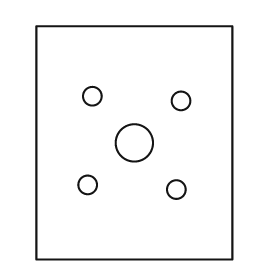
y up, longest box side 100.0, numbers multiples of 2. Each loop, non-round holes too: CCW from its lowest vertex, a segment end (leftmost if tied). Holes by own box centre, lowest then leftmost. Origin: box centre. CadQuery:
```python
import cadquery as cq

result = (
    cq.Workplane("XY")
    .moveTo(-42.0, -50.0)
    .lineTo(42.0, -50.0)
    .lineTo(42.0, 50.0)
    .lineTo(-42.0, 50.0)
    .close()
    .moveTo(18.0, -20.0)
    .circle(4.0)
    .moveTo(-20.0, -18.0)
    .circle(4.0)
    .moveTo(0.0, 0.0)
    .circle(8.0)
    .moveTo(20.0, 18.0)
    .circle(4.0)
    .moveTo(-18.0, 20.0)
    .circle(4.0)
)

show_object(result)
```